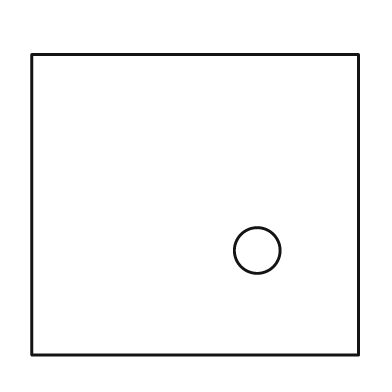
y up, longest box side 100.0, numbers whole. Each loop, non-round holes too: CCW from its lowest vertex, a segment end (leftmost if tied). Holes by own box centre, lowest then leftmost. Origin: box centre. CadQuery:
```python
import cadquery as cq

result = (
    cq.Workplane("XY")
    .moveTo(-50.0, -46.0)
    .lineTo(50.0, -46.0)
    .lineTo(50.0, 46.0)
    .lineTo(-50.0, 46.0)
    .close()
    .moveTo(19.0, -14.0)
    .circle(7.0)
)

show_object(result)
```